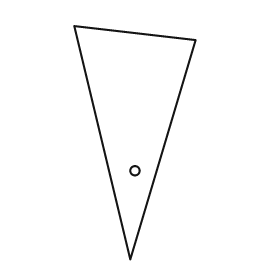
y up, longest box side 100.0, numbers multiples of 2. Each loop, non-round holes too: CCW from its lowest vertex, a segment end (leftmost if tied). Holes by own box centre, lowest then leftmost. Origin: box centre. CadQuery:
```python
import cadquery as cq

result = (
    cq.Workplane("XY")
    .moveTo(-2.0, -50.0)
    .lineTo(26.0, 44.0)
    .lineTo(-26.0, 50.0)
    .close()
    .moveTo(0.0, -12.0)
    .circle(2.0)
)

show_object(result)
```